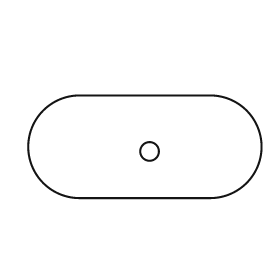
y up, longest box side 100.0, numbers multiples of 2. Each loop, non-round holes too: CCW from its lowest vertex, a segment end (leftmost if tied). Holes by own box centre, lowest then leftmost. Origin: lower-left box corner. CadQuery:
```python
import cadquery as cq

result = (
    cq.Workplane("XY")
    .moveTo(22.0, 0.0)
    .lineTo(78.0, 0.0)
    .threePointArc((100.0, 22.0), (78.0, 44.0))
    .lineTo(22.0, 44.0)
    .threePointArc((0.0, 22.0), (22.0, 0.0))
    .close()
    .moveTo(52.0, 20.0)
    .circle(4.0)
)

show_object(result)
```